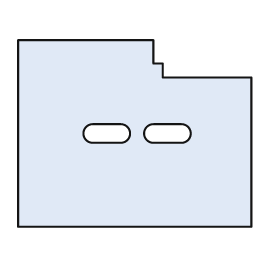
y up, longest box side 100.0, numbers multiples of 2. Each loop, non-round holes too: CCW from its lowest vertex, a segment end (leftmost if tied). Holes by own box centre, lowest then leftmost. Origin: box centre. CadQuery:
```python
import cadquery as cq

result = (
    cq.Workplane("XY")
    .moveTo(-50.0, -40.0)
    .lineTo(50.0, -40.0)
    .lineTo(50.0, 24.0)
    .lineTo(12.0, 24.0)
    .lineTo(12.0, 30.0)
    .lineTo(8.0, 30.0)
    .lineTo(8.0, 40.0)
    .lineTo(-50.0, 40.0)
    .close()
    .moveTo(-18.0, -4.0)
    .lineTo(-6.0, -4.0)
    .threePointArc((-2.0, 0.0), (-6.0, 4.0))
    .lineTo(-18.0, 4.0)
    .threePointArc((-22.0, 0.0), (-18.0, -4.0))
    .close()
    .moveTo(8.0, -4.0)
    .lineTo(20.0, -4.0)
    .threePointArc((24.0, 0.0), (20.0, 4.0))
    .lineTo(8.0, 4.0)
    .threePointArc((4.0, 0.0), (8.0, -4.0))
    .close()
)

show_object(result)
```